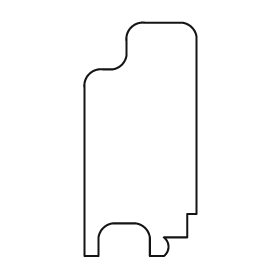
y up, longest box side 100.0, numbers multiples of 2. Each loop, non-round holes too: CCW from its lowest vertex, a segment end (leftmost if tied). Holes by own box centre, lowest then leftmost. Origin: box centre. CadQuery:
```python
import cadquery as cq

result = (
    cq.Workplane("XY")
    .moveTo(-24.0, -50.0)
    .lineTo(-18.0, -50.0)
    .lineTo(-18.0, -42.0)
    .threePointArc((-16.0, -38.0), (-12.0, -36.0))
    .lineTo(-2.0, -36.0)
    .threePointArc((2.0, -38.0), (4.0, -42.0))
    .lineTo(4.0, -50.0)
    .lineTo(10.0, -50.0)
    .threePointArc((12.0, -46.0), (10.0, -42.0))
    .lineTo(20.0, -42.0)
    .lineTo(20.0, -32.0)
    .lineTo(24.0, -32.0)
    .lineTo(24.0, 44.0)
    .threePointArc((22.0, 48.0), (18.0, 50.0))
    .lineTo(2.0, 50.0)
    .threePointArc((-4.0, 48.0), (-6.0, 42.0))
    .lineTo(-6.0, 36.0)
    .threePointArc((-8.0, 32.0), (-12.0, 30.0))
    .lineTo(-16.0, 30.0)
    .threePointArc((-22.0, 28.0), (-24.0, 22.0))
    .close()
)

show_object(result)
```